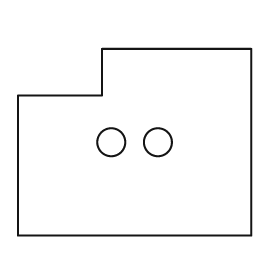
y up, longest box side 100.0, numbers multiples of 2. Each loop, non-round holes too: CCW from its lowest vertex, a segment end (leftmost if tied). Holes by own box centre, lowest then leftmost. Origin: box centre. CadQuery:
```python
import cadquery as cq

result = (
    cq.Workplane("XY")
    .moveTo(-50.0, -40.0)
    .lineTo(50.0, -40.0)
    .lineTo(50.0, 40.0)
    .lineTo(-14.0, 40.0)
    .lineTo(-14.0, 20.0)
    .lineTo(-50.0, 20.0)
    .close()
    .moveTo(-10.0, 0.0)
    .circle(6.0)
    .moveTo(10.0, 0.0)
    .circle(6.0)
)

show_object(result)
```